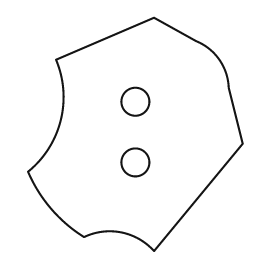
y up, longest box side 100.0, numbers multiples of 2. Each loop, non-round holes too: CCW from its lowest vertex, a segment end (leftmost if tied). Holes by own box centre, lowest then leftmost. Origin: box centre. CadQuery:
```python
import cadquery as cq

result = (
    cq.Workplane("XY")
    .moveTo(8.0, -50.0)
    .lineTo(46.0, -4.0)
    .lineTo(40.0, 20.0)
    .threePointArc((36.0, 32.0), (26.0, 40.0))
    .lineTo(8.0, 50.0)
    .lineTo(-34.0, 32.0)
    .threePointArc((-32.0, 6.0), (-46.0, -16.0))
    .threePointArc((-36.0, -32.0), (-22.0, -44.0))
    .threePointArc((-6.0, -42.0), (8.0, -50.0))
    .close()
    .moveTo(0.0, -12.0)
    .circle(6.0)
    .moveTo(0.0, 14.0)
    .circle(6.0)
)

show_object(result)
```